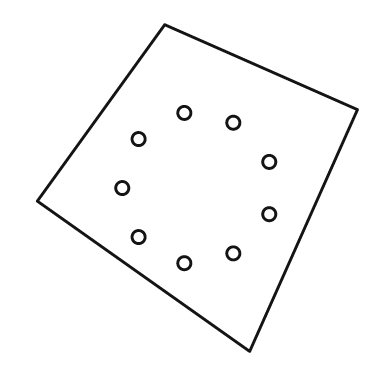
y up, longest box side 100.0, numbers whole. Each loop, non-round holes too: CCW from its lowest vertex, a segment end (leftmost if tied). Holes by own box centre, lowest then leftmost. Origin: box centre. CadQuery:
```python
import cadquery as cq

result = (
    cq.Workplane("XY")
    .moveTo(16.0, -50.0)
    .lineTo(49.0, 24.0)
    .lineTo(-10.0, 50.0)
    .lineTo(-49.0, -4.0)
    .close()
    .moveTo(-4.0, -23.0)
    .circle(2.0)
    .moveTo(11.0, -20.0)
    .circle(2.0)
    .moveTo(-18.0, -15.0)
    .circle(2.0)
    .moveTo(22.0, -8.0)
    .circle(2.0)
    .moveTo(-23.0, 0.0)
    .circle(2.0)
    .moveTo(22.0, 8.0)
    .circle(2.0)
    .moveTo(-18.0, 15.0)
    .circle(2.0)
    .moveTo(11.0, 20.0)
    .circle(2.0)
    .moveTo(-4.0, 23.0)
    .circle(2.0)
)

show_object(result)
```